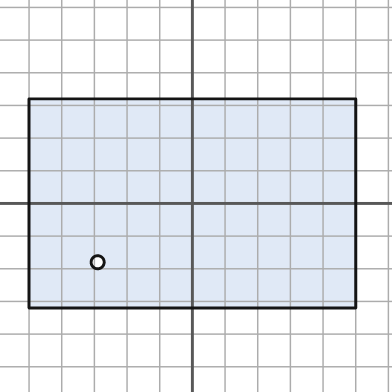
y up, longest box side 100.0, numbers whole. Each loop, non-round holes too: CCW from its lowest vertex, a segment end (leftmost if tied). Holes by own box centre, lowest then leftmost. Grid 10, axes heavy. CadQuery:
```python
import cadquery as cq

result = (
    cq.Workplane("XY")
    .moveTo(-50.0, -32.0)
    .lineTo(50.0, -32.0)
    .lineTo(50.0, 32.0)
    .lineTo(-50.0, 32.0)
    .close()
    .moveTo(-29.0, -18.0)
    .circle(2.0)
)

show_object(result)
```